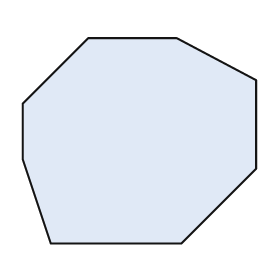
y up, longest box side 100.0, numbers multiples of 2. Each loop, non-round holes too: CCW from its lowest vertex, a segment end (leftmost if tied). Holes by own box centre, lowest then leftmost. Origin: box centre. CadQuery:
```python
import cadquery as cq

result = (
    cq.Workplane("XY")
    .moveTo(-38.0, -44.0)
    .lineTo(18.0, -44.0)
    .lineTo(50.0, -12.0)
    .lineTo(50.0, 26.0)
    .lineTo(16.0, 44.0)
    .lineTo(-22.0, 44.0)
    .lineTo(-50.0, 16.0)
    .lineTo(-50.0, -8.0)
    .close()
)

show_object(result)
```